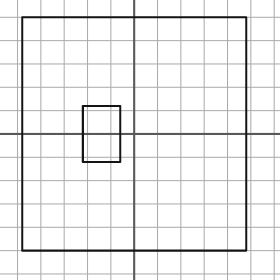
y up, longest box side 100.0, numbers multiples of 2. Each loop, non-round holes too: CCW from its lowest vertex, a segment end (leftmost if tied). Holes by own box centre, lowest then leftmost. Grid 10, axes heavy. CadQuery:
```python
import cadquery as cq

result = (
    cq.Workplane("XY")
    .moveTo(-48.0, -50.0)
    .lineTo(48.0, -50.0)
    .lineTo(48.0, 50.0)
    .lineTo(-48.0, 50.0)
    .close()
    .moveTo(-22.0, -12.0)
    .lineTo(-6.0, -12.0)
    .lineTo(-6.0, 12.0)
    .lineTo(-22.0, 12.0)
    .close()
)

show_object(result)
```